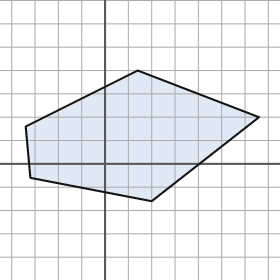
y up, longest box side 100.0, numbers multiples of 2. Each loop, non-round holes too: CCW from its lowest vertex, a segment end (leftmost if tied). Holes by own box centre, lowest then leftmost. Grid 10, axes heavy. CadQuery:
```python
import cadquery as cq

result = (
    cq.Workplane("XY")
    .moveTo(20.0, -16.0)
    .lineTo(66.0, 20.0)
    .lineTo(14.0, 40.0)
    .lineTo(-34.0, 16.0)
    .lineTo(-32.0, -6.0)
    .close()
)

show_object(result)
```